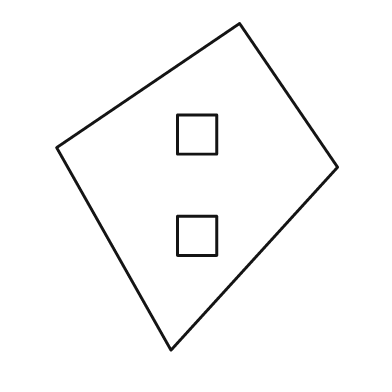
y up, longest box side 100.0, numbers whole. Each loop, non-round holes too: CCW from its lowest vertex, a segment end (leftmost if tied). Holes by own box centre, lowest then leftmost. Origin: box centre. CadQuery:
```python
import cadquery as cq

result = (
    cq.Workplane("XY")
    .moveTo(-8.0, -50.0)
    .lineTo(43.0, 6.0)
    .lineTo(13.0, 50.0)
    .lineTo(-43.0, 12.0)
    .close()
    .moveTo(-6.0, -21.0)
    .lineTo(6.0, -21.0)
    .lineTo(6.0, -9.0)
    .lineTo(-6.0, -9.0)
    .close()
    .moveTo(-6.0, 10.0)
    .lineTo(6.0, 10.0)
    .lineTo(6.0, 22.0)
    .lineTo(-6.0, 22.0)
    .close()
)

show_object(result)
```